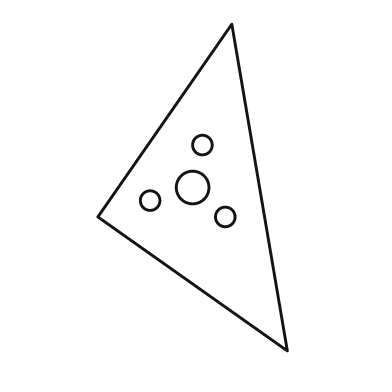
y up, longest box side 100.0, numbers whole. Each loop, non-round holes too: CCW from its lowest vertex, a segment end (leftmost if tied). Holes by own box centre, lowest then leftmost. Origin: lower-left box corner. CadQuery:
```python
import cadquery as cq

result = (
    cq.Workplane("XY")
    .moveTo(58.0, 0.0)
    .lineTo(41.0, 100.0)
    .lineTo(0.0, 41.0)
    .close()
    .moveTo(39.0, 41.0)
    .circle(3.0)
    .moveTo(16.0, 46.0)
    .circle(3.0)
    .moveTo(29.0, 50.0)
    .circle(5.0)
    .moveTo(32.0, 63.0)
    .circle(3.0)
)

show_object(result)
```